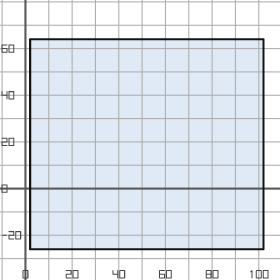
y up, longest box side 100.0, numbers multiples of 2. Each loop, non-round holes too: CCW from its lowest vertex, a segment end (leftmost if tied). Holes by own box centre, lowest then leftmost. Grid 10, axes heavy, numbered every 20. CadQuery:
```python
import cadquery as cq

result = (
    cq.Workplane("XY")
    .moveTo(2.0, -26.0)
    .lineTo(102.0, -26.0)
    .lineTo(102.0, 64.0)
    .lineTo(2.0, 64.0)
    .close()
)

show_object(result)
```